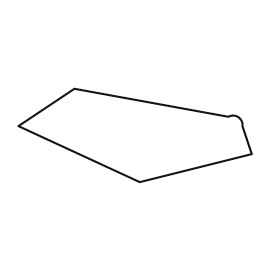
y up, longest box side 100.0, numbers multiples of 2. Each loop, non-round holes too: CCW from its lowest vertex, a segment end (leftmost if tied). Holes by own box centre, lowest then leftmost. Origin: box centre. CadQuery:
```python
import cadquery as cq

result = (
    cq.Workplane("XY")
    .moveTo(2.0, -20.0)
    .lineTo(50.0, -8.0)
    .lineTo(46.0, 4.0)
    .threePointArc((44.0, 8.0), (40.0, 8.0))
    .lineTo(-26.0, 20.0)
    .lineTo(-50.0, 4.0)
    .close()
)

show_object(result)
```